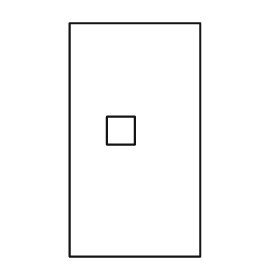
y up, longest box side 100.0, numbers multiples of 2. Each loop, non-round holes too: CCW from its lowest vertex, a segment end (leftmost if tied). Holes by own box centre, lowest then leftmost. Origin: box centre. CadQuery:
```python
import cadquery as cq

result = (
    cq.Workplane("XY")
    .moveTo(-28.0, -50.0)
    .lineTo(28.0, -50.0)
    .lineTo(28.0, 50.0)
    .lineTo(-28.0, 50.0)
    .close()
    .moveTo(-12.0, -2.0)
    .lineTo(0.0, -2.0)
    .lineTo(0.0, 10.0)
    .lineTo(-12.0, 10.0)
    .close()
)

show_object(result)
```